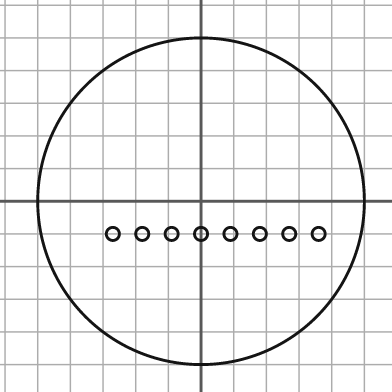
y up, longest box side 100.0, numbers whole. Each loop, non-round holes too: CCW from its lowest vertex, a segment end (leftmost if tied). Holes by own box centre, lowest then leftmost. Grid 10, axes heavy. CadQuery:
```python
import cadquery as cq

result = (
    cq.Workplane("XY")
    .moveTo(0.0, 0.0)
    .circle(50.0)
    .moveTo(-27.0, -10.0)
    .circle(2.0)
    .moveTo(-18.0, -10.0)
    .circle(2.0)
    .moveTo(-9.0, -10.0)
    .circle(2.0)
    .moveTo(0.0, -10.0)
    .circle(2.0)
    .moveTo(9.0, -10.0)
    .circle(2.0)
    .moveTo(18.0, -10.0)
    .circle(2.0)
    .moveTo(27.0, -10.0)
    .circle(2.0)
    .moveTo(36.0, -10.0)
    .circle(2.0)
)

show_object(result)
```